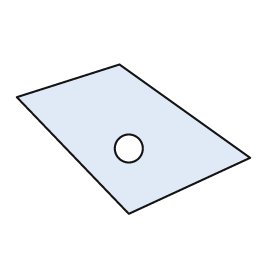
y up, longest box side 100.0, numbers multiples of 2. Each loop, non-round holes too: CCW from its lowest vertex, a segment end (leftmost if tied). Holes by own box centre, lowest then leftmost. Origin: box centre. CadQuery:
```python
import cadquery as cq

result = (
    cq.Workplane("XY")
    .moveTo(-2.0, -32.0)
    .lineTo(50.0, -8.0)
    .lineTo(-6.0, 32.0)
    .lineTo(-50.0, 18.0)
    .close()
    .moveTo(-2.0, -4.0)
    .circle(6.0)
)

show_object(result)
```